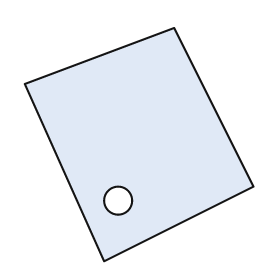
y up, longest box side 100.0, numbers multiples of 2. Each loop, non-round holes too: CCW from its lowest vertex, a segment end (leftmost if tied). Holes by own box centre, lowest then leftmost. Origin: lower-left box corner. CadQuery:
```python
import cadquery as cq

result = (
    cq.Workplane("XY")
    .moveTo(34.0, 0.0)
    .lineTo(98.0, 32.0)
    .lineTo(64.0, 100.0)
    .lineTo(0.0, 76.0)
    .close()
    .moveTo(40.0, 26.0)
    .circle(6.0)
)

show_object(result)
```